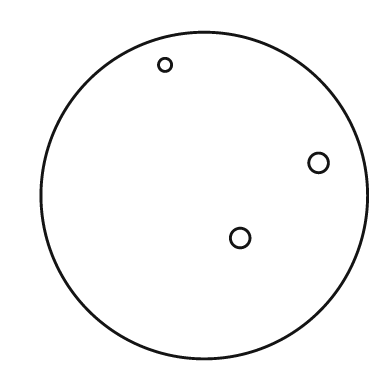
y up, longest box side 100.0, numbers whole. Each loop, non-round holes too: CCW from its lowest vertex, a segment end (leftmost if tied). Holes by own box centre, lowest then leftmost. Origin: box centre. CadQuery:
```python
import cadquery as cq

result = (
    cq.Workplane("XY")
    .moveTo(0.0, 0.0)
    .circle(50.0)
    .moveTo(11.0, -13.0)
    .circle(3.0)
    .moveTo(35.0, 10.0)
    .circle(3.0)
    .moveTo(-12.0, 40.0)
    .circle(2.0)
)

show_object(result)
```